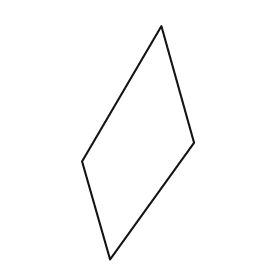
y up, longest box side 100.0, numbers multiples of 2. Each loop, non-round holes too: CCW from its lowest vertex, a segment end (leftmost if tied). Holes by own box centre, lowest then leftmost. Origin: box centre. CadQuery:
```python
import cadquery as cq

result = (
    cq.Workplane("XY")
    .moveTo(-12.0, -50.0)
    .lineTo(24.0, 0.0)
    .lineTo(10.0, 50.0)
    .lineTo(-24.0, -8.0)
    .close()
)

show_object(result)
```